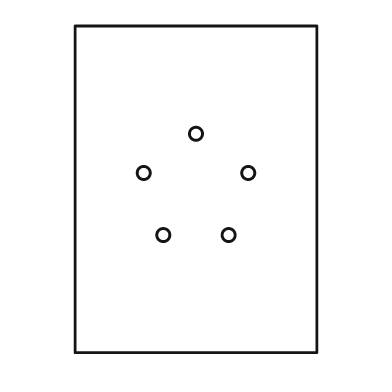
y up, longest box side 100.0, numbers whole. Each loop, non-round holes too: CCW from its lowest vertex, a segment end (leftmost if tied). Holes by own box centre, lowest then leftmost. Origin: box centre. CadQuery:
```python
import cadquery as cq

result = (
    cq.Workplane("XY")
    .moveTo(-37.0, -50.0)
    .lineTo(37.0, -50.0)
    .lineTo(37.0, 50.0)
    .lineTo(-37.0, 50.0)
    .close()
    .moveTo(-10.0, -14.0)
    .circle(2.0)
    .moveTo(10.0, -14.0)
    .circle(2.0)
    .moveTo(-16.0, 5.0)
    .circle(2.0)
    .moveTo(16.0, 5.0)
    .circle(2.0)
    .moveTo(0.0, 17.0)
    .circle(2.0)
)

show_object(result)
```